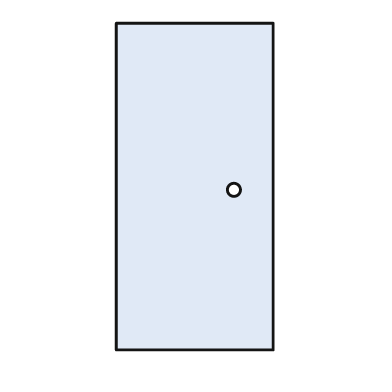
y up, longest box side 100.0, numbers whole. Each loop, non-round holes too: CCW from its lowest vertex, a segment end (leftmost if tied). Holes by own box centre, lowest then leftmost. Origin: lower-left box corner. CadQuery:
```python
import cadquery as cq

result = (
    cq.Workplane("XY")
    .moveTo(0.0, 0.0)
    .lineTo(48.0, 0.0)
    .lineTo(48.0, 100.0)
    .lineTo(0.0, 100.0)
    .close()
    .moveTo(36.0, 49.0)
    .circle(2.0)
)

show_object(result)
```